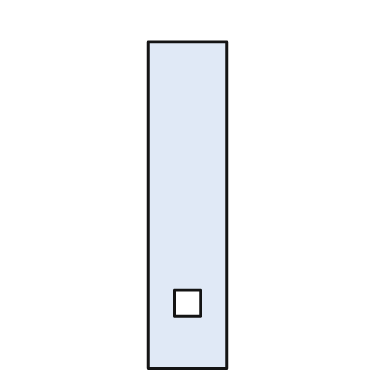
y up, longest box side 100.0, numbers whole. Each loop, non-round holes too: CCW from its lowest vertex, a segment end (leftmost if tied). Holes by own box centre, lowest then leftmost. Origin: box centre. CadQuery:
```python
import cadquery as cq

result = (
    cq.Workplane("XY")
    .moveTo(-12.0, -50.0)
    .lineTo(12.0, -50.0)
    .lineTo(12.0, 50.0)
    .lineTo(-12.0, 50.0)
    .close()
    .moveTo(-4.0, -34.0)
    .lineTo(4.0, -34.0)
    .lineTo(4.0, -26.0)
    .lineTo(-4.0, -26.0)
    .close()
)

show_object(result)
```